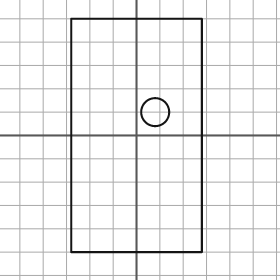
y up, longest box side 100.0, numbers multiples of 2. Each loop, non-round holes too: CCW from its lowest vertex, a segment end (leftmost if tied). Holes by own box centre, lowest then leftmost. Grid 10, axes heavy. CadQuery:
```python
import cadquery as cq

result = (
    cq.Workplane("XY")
    .moveTo(-28.0, -50.0)
    .lineTo(28.0, -50.0)
    .lineTo(28.0, 50.0)
    .lineTo(-28.0, 50.0)
    .close()
    .moveTo(8.0, 10.0)
    .circle(6.0)
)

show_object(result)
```